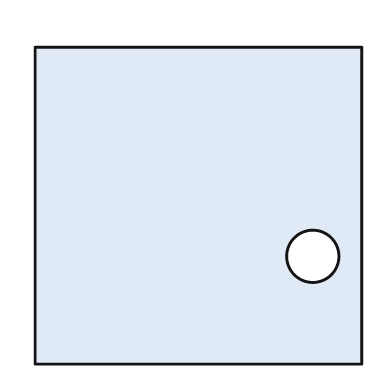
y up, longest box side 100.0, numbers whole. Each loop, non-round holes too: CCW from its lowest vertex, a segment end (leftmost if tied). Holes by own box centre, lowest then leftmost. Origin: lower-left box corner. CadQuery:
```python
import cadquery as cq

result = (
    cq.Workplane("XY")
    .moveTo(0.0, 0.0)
    .lineTo(100.0, 0.0)
    .lineTo(100.0, 97.0)
    .lineTo(0.0, 97.0)
    .close()
    .moveTo(85.0, 33.0)
    .circle(8.0)
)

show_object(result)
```